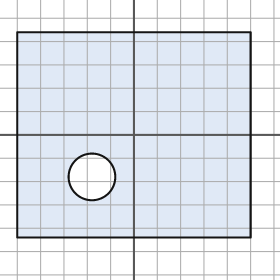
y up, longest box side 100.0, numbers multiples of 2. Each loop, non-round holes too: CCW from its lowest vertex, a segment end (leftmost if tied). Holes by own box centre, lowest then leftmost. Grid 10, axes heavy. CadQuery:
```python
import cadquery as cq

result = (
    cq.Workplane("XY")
    .moveTo(-50.0, -44.0)
    .lineTo(50.0, -44.0)
    .lineTo(50.0, 44.0)
    .lineTo(-50.0, 44.0)
    .close()
    .moveTo(-18.0, -18.0)
    .circle(10.0)
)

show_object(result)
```